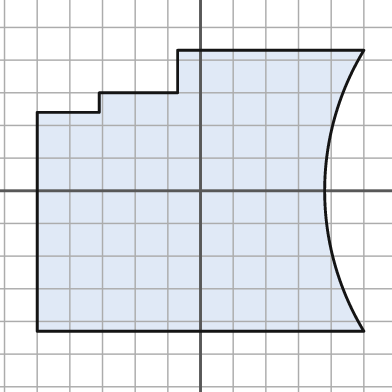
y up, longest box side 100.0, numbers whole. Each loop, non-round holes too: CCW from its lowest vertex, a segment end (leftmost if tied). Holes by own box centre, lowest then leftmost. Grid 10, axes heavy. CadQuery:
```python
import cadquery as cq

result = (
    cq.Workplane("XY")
    .moveTo(-50.0, -43.0)
    .lineTo(50.0, -43.0)
    .threePointArc((38.0, 0.0), (50.0, 43.0))
    .lineTo(-7.0, 43.0)
    .lineTo(-7.0, 30.0)
    .lineTo(-31.0, 30.0)
    .lineTo(-31.0, 24.0)
    .lineTo(-50.0, 24.0)
    .close()
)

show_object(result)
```